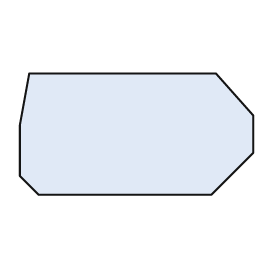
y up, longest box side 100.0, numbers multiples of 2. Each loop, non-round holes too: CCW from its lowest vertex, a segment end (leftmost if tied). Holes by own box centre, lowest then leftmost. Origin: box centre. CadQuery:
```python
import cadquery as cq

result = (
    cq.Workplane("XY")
    .moveTo(-42.0, -26.0)
    .lineTo(32.0, -26.0)
    .lineTo(50.0, -8.0)
    .lineTo(50.0, 8.0)
    .lineTo(34.0, 26.0)
    .lineTo(-46.0, 26.0)
    .lineTo(-50.0, 4.0)
    .lineTo(-50.0, -18.0)
    .close()
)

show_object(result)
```